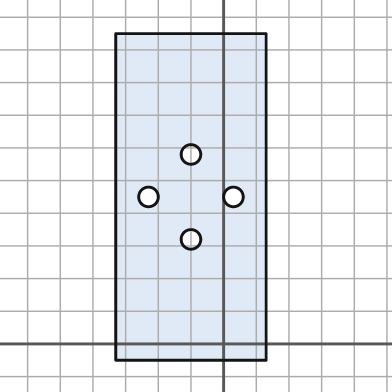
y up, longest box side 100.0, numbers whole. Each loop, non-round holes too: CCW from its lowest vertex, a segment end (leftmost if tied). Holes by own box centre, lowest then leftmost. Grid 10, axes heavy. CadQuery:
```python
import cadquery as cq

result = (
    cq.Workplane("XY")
    .moveTo(-33.0, -5.0)
    .lineTo(13.0, -5.0)
    .lineTo(13.0, 95.0)
    .lineTo(-33.0, 95.0)
    .close()
    .moveTo(-10.0, 32.0)
    .circle(3.0)
    .moveTo(-23.0, 45.0)
    .circle(3.0)
    .moveTo(3.0, 45.0)
    .circle(3.0)
    .moveTo(-10.0, 58.0)
    .circle(3.0)
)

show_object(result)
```